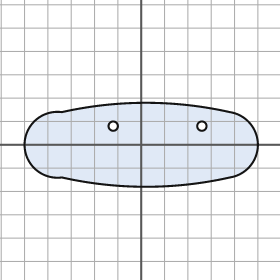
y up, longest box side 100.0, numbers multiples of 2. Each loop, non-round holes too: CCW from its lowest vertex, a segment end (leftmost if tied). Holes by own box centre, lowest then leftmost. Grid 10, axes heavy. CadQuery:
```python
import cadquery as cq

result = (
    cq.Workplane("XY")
    .moveTo(-34.0, -14.0)
    .threePointArc((2.0, -18.0), (38.0, -14.0))
    .threePointArc((50.0, 0.0), (38.0, 14.0))
    .threePointArc((2.0, 18.0), (-34.0, 14.0))
    .threePointArc((-50.0, 0.0), (-34.0, -14.0))
    .close()
    .moveTo(-12.0, 8.0)
    .circle(2.0)
    .moveTo(26.0, 8.0)
    .circle(2.0)
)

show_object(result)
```